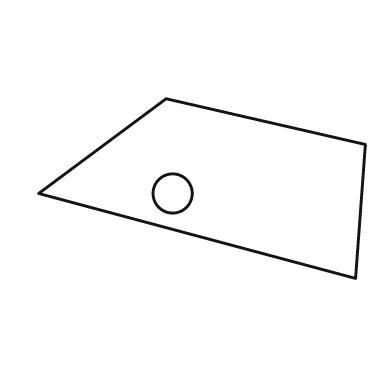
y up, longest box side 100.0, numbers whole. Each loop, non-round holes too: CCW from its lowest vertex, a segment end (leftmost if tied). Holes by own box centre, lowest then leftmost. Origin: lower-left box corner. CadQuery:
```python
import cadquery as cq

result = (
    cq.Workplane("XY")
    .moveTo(97.0, 0.0)
    .lineTo(100.0, 41.0)
    .lineTo(39.0, 55.0)
    .lineTo(0.0, 26.0)
    .close()
    .moveTo(41.0, 26.0)
    .circle(6.0)
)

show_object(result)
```